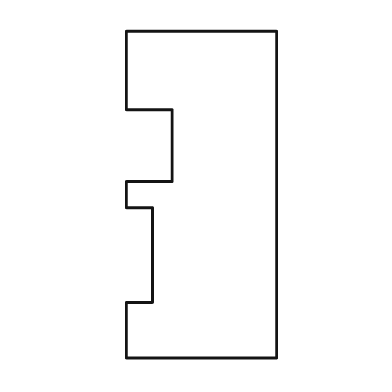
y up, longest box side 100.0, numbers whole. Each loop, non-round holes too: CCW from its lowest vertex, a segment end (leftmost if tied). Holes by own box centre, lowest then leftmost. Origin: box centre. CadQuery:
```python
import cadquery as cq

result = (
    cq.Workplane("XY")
    .moveTo(-23.0, -50.0)
    .lineTo(23.0, -50.0)
    .lineTo(23.0, 50.0)
    .lineTo(-23.0, 50.0)
    .lineTo(-23.0, 26.0)
    .lineTo(-9.0, 26.0)
    .lineTo(-9.0, 4.0)
    .lineTo(-23.0, 4.0)
    .lineTo(-23.0, -4.0)
    .lineTo(-15.0, -4.0)
    .lineTo(-15.0, -33.0)
    .lineTo(-23.0, -33.0)
    .close()
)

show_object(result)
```